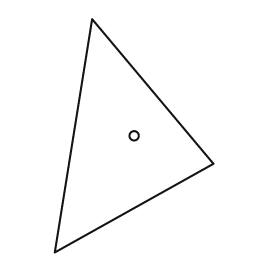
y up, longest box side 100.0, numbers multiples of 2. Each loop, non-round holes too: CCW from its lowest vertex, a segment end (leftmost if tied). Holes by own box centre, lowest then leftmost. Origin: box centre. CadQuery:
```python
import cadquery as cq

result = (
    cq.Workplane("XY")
    .moveTo(-34.0, -50.0)
    .lineTo(34.0, -12.0)
    .lineTo(-18.0, 50.0)
    .close()
    .moveTo(0.0, 0.0)
    .circle(2.0)
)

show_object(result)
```